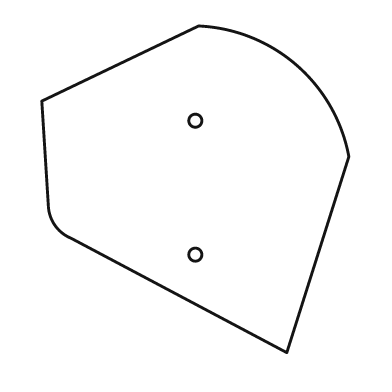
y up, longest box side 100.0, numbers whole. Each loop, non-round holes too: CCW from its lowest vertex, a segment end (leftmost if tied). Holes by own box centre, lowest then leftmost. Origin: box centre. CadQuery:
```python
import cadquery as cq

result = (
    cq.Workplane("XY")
    .moveTo(28.0, -50.0)
    .lineTo(47.0, 10.0)
    .threePointArc((31.0, 38.0), (1.0, 50.0))
    .lineTo(-47.0, 27.0)
    .lineTo(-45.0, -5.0)
    .threePointArc((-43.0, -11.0), (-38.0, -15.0))
    .close()
    .moveTo(0.0, -20.0)
    .circle(2.0)
    .moveTo(0.0, 21.0)
    .circle(2.0)
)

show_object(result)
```